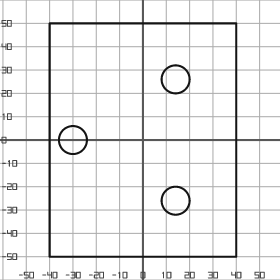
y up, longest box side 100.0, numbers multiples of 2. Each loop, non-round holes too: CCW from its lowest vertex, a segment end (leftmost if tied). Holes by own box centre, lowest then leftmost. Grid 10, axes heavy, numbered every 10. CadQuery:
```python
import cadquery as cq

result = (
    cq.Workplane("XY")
    .moveTo(-40.0, -50.0)
    .lineTo(40.0, -50.0)
    .lineTo(40.0, 50.0)
    .lineTo(-40.0, 50.0)
    .close()
    .moveTo(14.0, -26.0)
    .circle(6.0)
    .moveTo(-30.0, 0.0)
    .circle(6.0)
    .moveTo(14.0, 26.0)
    .circle(6.0)
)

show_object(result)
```